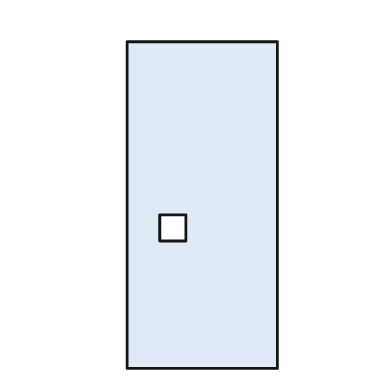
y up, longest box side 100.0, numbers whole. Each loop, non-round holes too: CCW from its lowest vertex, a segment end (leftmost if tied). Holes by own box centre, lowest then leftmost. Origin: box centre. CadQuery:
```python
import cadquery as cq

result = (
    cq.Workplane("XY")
    .moveTo(-23.0, -50.0)
    .lineTo(23.0, -50.0)
    .lineTo(23.0, 50.0)
    .lineTo(-23.0, 50.0)
    .close()
    .moveTo(-13.0, -11.0)
    .lineTo(-5.0, -11.0)
    .lineTo(-5.0, -3.0)
    .lineTo(-13.0, -3.0)
    .close()
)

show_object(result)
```